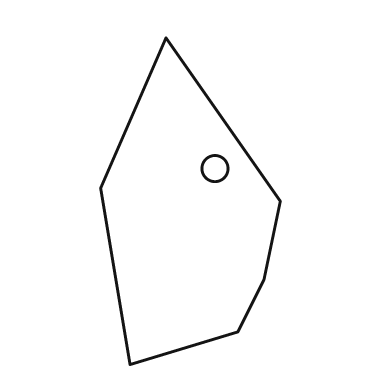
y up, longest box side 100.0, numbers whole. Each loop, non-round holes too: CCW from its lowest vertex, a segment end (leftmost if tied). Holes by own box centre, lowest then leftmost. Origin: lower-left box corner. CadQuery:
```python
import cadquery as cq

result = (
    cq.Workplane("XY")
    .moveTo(9.0, 0.0)
    .lineTo(42.0, 10.0)
    .lineTo(50.0, 26.0)
    .lineTo(55.0, 50.0)
    .lineTo(20.0, 100.0)
    .lineTo(0.0, 54.0)
    .close()
    .moveTo(35.0, 60.0)
    .circle(4.0)
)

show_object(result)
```